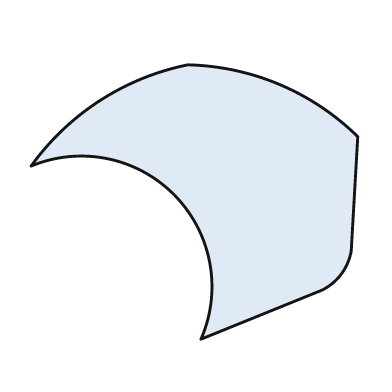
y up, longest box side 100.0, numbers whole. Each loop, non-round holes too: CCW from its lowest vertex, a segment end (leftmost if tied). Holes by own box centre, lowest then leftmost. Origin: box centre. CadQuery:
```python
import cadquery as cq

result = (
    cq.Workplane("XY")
    .moveTo(2.0, -42.0)
    .lineTo(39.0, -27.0)
    .threePointArc((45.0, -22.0), (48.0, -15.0))
    .lineTo(50.0, 20.0)
    .threePointArc((26.0, 36.0), (-2.0, 42.0))
    .threePointArc((-29.0, 31.0), (-50.0, 11.0))
    .threePointArc((-6.0, 2.0), (2.0, -42.0))
    .close()
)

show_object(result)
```